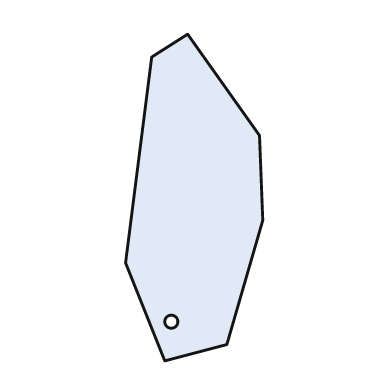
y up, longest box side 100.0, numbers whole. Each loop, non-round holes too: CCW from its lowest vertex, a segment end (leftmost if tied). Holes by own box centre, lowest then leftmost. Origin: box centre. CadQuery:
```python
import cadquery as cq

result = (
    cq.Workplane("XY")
    .moveTo(-9.0, -50.0)
    .lineTo(10.0, -45.0)
    .lineTo(21.0, -7.0)
    .lineTo(20.0, 19.0)
    .lineTo(-2.0, 50.0)
    .lineTo(-13.0, 43.0)
    .lineTo(-21.0, -20.0)
    .close()
    .moveTo(-7.0, -38.0)
    .circle(2.0)
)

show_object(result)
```